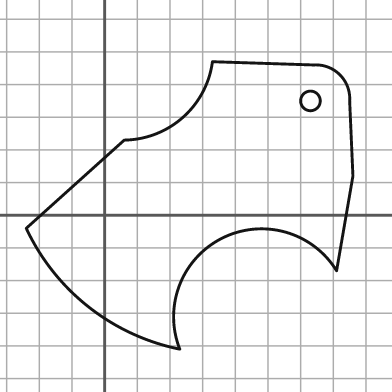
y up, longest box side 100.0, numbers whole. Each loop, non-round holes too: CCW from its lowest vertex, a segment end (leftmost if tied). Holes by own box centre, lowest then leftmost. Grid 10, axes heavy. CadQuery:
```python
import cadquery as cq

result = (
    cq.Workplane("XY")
    .moveTo(23.0, -41.0)
    .threePointArc((36.0, -7.0), (71.0, -17.0))
    .lineTo(76.0, 12.0)
    .lineTo(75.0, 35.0)
    .threePointArc((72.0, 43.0), (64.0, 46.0))
    .lineTo(33.0, 47.0)
    .threePointArc((24.0, 30.0), (6.0, 23.0))
    .lineTo(-24.0, -4.0)
    .threePointArc((-5.0, -28.0), (23.0, -41.0))
    .close()
    .moveTo(63.0, 35.0)
    .circle(3.0)
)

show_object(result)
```